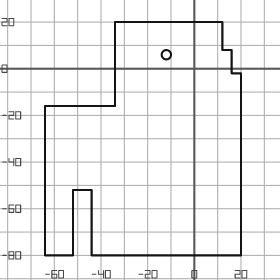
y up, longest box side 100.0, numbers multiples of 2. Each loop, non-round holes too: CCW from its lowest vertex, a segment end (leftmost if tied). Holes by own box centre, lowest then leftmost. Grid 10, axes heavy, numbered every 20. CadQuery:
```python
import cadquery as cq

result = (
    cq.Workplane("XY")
    .moveTo(-64.0, -80.0)
    .lineTo(-52.0, -80.0)
    .lineTo(-52.0, -52.0)
    .lineTo(-44.0, -52.0)
    .lineTo(-44.0, -80.0)
    .lineTo(20.0, -80.0)
    .lineTo(20.0, -2.0)
    .lineTo(16.0, -2.0)
    .lineTo(16.0, 8.0)
    .lineTo(12.0, 8.0)
    .lineTo(12.0, 20.0)
    .lineTo(-34.0, 20.0)
    .lineTo(-34.0, -16.0)
    .lineTo(-64.0, -16.0)
    .close()
    .moveTo(-12.0, 6.0)
    .circle(2.0)
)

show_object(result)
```